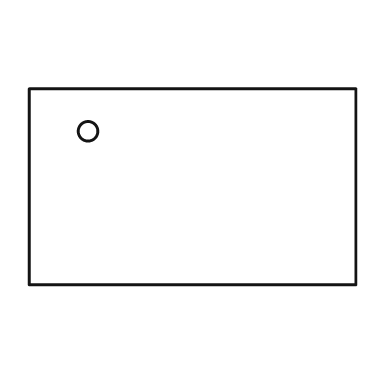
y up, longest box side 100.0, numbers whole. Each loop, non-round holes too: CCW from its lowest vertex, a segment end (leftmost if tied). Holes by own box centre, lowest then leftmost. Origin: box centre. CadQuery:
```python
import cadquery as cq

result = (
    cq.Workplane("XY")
    .moveTo(-50.0, -30.0)
    .lineTo(50.0, -30.0)
    .lineTo(50.0, 30.0)
    .lineTo(-50.0, 30.0)
    .close()
    .moveTo(-32.0, 17.0)
    .circle(3.0)
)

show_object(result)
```